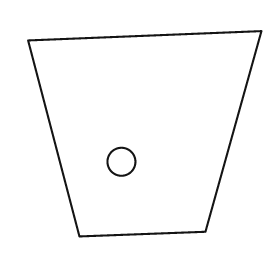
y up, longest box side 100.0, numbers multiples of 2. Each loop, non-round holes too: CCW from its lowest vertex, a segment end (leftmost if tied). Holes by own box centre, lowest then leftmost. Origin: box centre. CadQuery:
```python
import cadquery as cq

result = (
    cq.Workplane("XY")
    .moveTo(-28.0, -44.0)
    .lineTo(26.0, -42.0)
    .lineTo(50.0, 44.0)
    .lineTo(-50.0, 40.0)
    .close()
    .moveTo(-10.0, -12.0)
    .circle(6.0)
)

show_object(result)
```